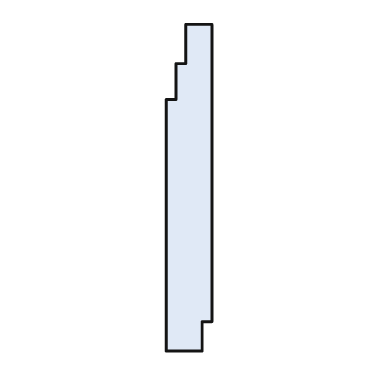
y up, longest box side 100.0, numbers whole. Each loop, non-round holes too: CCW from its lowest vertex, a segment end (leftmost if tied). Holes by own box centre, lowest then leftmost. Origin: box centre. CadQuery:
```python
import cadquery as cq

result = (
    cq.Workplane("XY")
    .moveTo(-7.0, -50.0)
    .lineTo(4.0, -50.0)
    .lineTo(4.0, -41.0)
    .lineTo(7.0, -41.0)
    .lineTo(7.0, 50.0)
    .lineTo(-1.0, 50.0)
    .lineTo(-1.0, 38.0)
    .lineTo(-4.0, 38.0)
    .lineTo(-4.0, 27.0)
    .lineTo(-7.0, 27.0)
    .close()
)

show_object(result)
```